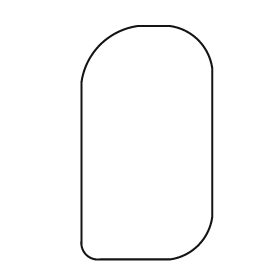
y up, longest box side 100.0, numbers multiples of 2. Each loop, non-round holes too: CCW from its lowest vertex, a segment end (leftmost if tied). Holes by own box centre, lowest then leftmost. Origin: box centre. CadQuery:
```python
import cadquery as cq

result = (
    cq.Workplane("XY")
    .moveTo(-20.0, -50.0)
    .lineTo(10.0, -50.0)
    .threePointArc((22.0, -44.0), (28.0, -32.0))
    .lineTo(28.0, 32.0)
    .threePointArc((22.0, 44.0), (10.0, 50.0))
    .lineTo(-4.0, 50.0)
    .threePointArc((-20.0, 42.0), (-28.0, 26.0))
    .lineTo(-28.0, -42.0)
    .threePointArc((-26.0, -48.0), (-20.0, -50.0))
    .close()
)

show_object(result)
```